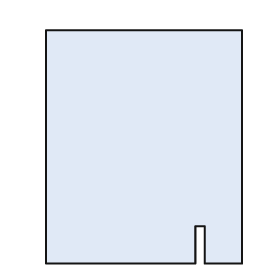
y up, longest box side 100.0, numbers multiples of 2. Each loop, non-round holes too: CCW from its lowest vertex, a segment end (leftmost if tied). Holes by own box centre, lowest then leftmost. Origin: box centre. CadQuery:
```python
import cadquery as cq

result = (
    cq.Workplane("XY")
    .moveTo(-42.0, -50.0)
    .lineTo(22.0, -50.0)
    .lineTo(22.0, -34.0)
    .lineTo(26.0, -34.0)
    .lineTo(26.0, -50.0)
    .lineTo(42.0, -50.0)
    .lineTo(42.0, 50.0)
    .lineTo(-42.0, 50.0)
    .close()
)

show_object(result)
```